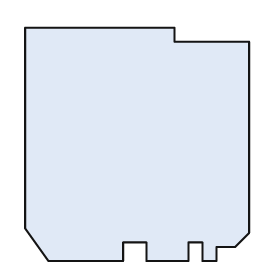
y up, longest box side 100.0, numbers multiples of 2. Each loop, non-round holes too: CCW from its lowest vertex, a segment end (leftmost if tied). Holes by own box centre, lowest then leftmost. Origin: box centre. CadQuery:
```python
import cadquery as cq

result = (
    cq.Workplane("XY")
    .moveTo(-38.0, -50.0)
    .lineTo(-6.0, -50.0)
    .lineTo(-6.0, -42.0)
    .lineTo(4.0, -42.0)
    .lineTo(4.0, -50.0)
    .lineTo(22.0, -50.0)
    .lineTo(22.0, -42.0)
    .lineTo(28.0, -42.0)
    .lineTo(28.0, -50.0)
    .lineTo(34.0, -50.0)
    .lineTo(34.0, -44.0)
    .lineTo(42.0, -44.0)
    .lineTo(48.0, -38.0)
    .lineTo(48.0, 44.0)
    .lineTo(16.0, 44.0)
    .lineTo(16.0, 50.0)
    .lineTo(-48.0, 50.0)
    .lineTo(-48.0, -36.0)
    .close()
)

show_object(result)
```